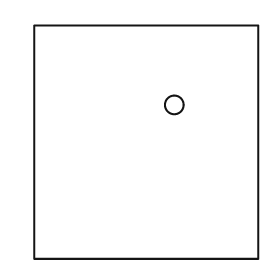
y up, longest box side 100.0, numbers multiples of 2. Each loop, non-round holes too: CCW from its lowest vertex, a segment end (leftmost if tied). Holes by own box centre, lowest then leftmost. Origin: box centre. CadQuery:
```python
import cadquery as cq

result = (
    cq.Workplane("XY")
    .moveTo(-48.0, -50.0)
    .lineTo(48.0, -50.0)
    .lineTo(48.0, 50.0)
    .lineTo(-48.0, 50.0)
    .close()
    .moveTo(12.0, 16.0)
    .circle(4.0)
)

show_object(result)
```